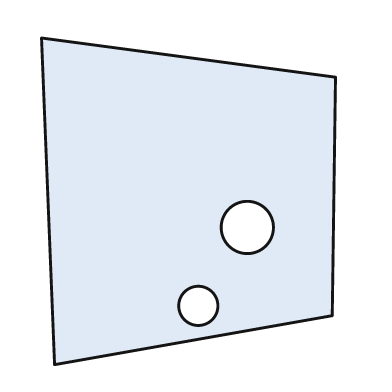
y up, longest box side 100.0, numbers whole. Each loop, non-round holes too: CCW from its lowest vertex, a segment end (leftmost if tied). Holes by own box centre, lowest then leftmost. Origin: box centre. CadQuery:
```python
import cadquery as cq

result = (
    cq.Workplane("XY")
    .moveTo(-41.0, -50.0)
    .lineTo(44.0, -35.0)
    .lineTo(45.0, 38.0)
    .lineTo(-45.0, 50.0)
    .close()
    .moveTo(3.0, -32.0)
    .circle(6.0)
    .moveTo(18.0, -8.0)
    .circle(8.0)
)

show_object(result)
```